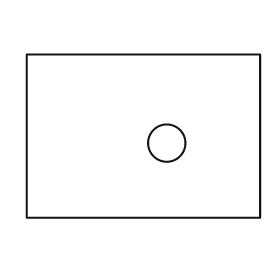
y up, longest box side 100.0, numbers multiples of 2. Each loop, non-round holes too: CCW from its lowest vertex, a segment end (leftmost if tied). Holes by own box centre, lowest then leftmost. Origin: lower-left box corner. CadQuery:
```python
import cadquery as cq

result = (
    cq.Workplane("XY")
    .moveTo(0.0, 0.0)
    .lineTo(100.0, 0.0)
    .lineTo(100.0, 70.0)
    .lineTo(0.0, 70.0)
    .close()
    .moveTo(60.0, 32.0)
    .circle(8.0)
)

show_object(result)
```